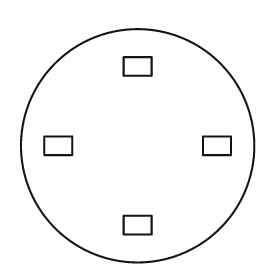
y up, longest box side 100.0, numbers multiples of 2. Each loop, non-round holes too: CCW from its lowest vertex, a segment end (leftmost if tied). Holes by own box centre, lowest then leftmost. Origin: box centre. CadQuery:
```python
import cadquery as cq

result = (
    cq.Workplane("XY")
    .moveTo(0.0, 0.0)
    .circle(50.0)
    .moveTo(-6.0, -38.0)
    .lineTo(6.0, -38.0)
    .lineTo(6.0, -30.0)
    .lineTo(-6.0, -30.0)
    .close()
    .moveTo(-40.0, -4.0)
    .lineTo(-28.0, -4.0)
    .lineTo(-28.0, 4.0)
    .lineTo(-40.0, 4.0)
    .close()
    .moveTo(28.0, -4.0)
    .lineTo(40.0, -4.0)
    .lineTo(40.0, 4.0)
    .lineTo(28.0, 4.0)
    .close()
    .moveTo(-6.0, 30.0)
    .lineTo(6.0, 30.0)
    .lineTo(6.0, 38.0)
    .lineTo(-6.0, 38.0)
    .close()
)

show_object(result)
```